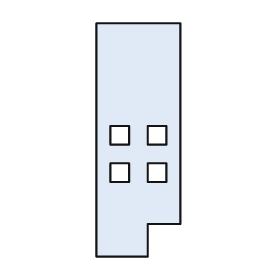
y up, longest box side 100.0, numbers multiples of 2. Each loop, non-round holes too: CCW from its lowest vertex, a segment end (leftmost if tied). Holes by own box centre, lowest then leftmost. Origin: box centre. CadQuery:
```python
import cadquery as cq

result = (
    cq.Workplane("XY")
    .moveTo(-18.0, -50.0)
    .lineTo(4.0, -50.0)
    .lineTo(4.0, -36.0)
    .lineTo(18.0, -36.0)
    .lineTo(18.0, 50.0)
    .lineTo(-18.0, 50.0)
    .close()
    .moveTo(-12.0, -18.0)
    .lineTo(-4.0, -18.0)
    .lineTo(-4.0, -10.0)
    .lineTo(-12.0, -10.0)
    .close()
    .moveTo(4.0, -18.0)
    .lineTo(12.0, -18.0)
    .lineTo(12.0, -10.0)
    .lineTo(4.0, -10.0)
    .close()
    .moveTo(-12.0, -2.0)
    .lineTo(-4.0, -2.0)
    .lineTo(-4.0, 6.0)
    .lineTo(-12.0, 6.0)
    .close()
    .moveTo(4.0, -2.0)
    .lineTo(12.0, -2.0)
    .lineTo(12.0, 6.0)
    .lineTo(4.0, 6.0)
    .close()
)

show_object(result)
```